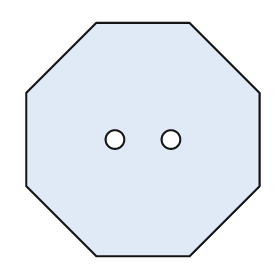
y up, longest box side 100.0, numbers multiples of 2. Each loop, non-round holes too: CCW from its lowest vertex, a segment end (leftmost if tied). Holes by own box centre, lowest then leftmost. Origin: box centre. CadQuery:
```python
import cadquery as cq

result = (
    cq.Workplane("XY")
    .moveTo(-20.0, -50.0)
    .lineTo(20.0, -50.0)
    .lineTo(50.0, -20.0)
    .lineTo(50.0, 20.0)
    .lineTo(20.0, 50.0)
    .lineTo(-20.0, 50.0)
    .lineTo(-50.0, 20.0)
    .lineTo(-50.0, -20.0)
    .close()
    .moveTo(-12.0, 0.0)
    .circle(4.0)
    .moveTo(12.0, 0.0)
    .circle(4.0)
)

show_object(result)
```